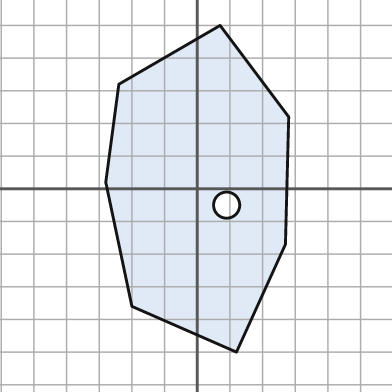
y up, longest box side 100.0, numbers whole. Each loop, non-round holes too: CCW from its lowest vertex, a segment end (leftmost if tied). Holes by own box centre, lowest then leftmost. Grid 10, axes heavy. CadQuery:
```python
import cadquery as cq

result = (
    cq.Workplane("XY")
    .moveTo(12.0, -50.0)
    .lineTo(27.0, -17.0)
    .lineTo(28.0, 22.0)
    .lineTo(7.0, 50.0)
    .lineTo(-24.0, 32.0)
    .lineTo(-28.0, 2.0)
    .lineTo(-20.0, -36.0)
    .close()
    .moveTo(9.0, -5.0)
    .circle(4.0)
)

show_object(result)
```